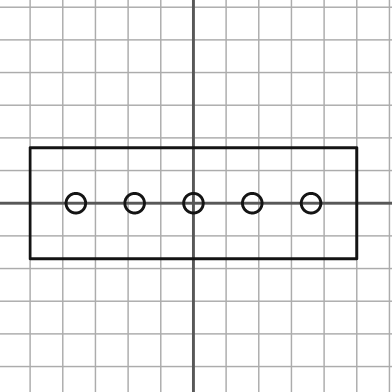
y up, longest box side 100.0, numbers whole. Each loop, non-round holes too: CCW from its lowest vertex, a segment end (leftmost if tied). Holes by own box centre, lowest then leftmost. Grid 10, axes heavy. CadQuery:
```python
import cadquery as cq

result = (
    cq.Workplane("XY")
    .moveTo(-50.0, -17.0)
    .lineTo(50.0, -17.0)
    .lineTo(50.0, 17.0)
    .lineTo(-50.0, 17.0)
    .close()
    .moveTo(-36.0, 0.0)
    .circle(3.0)
    .moveTo(-18.0, 0.0)
    .circle(3.0)
    .moveTo(0.0, 0.0)
    .circle(3.0)
    .moveTo(18.0, 0.0)
    .circle(3.0)
    .moveTo(36.0, 0.0)
    .circle(3.0)
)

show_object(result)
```